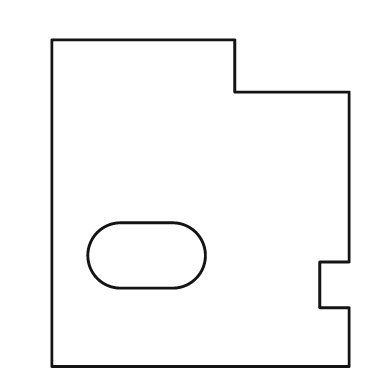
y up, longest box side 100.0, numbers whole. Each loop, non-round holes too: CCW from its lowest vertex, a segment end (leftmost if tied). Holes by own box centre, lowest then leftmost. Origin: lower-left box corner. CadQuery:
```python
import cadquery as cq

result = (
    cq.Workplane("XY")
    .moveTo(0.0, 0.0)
    .lineTo(91.0, 0.0)
    .lineTo(91.0, 18.0)
    .lineTo(82.0, 18.0)
    .lineTo(82.0, 32.0)
    .lineTo(91.0, 32.0)
    .lineTo(91.0, 84.0)
    .lineTo(56.0, 84.0)
    .lineTo(56.0, 100.0)
    .lineTo(0.0, 100.0)
    .close()
    .moveTo(21.0, 24.0)
    .lineTo(37.0, 24.0)
    .threePointArc((47.0, 34.0), (37.0, 44.0))
    .lineTo(21.0, 44.0)
    .threePointArc((11.0, 34.0), (21.0, 24.0))
    .close()
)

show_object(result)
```